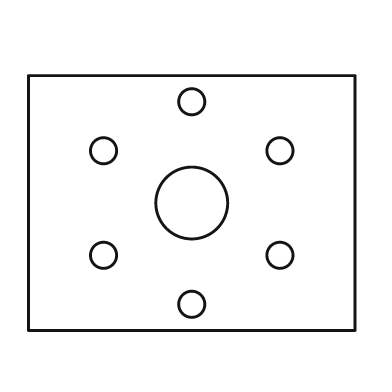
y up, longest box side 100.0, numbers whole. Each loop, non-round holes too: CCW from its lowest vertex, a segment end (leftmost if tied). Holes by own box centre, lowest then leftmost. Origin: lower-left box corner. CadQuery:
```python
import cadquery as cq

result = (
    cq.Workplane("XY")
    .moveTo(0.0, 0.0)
    .lineTo(100.0, 0.0)
    .lineTo(100.0, 78.0)
    .lineTo(0.0, 78.0)
    .close()
    .moveTo(50.0, 8.0)
    .circle(4.0)
    .moveTo(23.0, 23.0)
    .circle(4.0)
    .moveTo(77.0, 23.0)
    .circle(4.0)
    .moveTo(50.0, 39.0)
    .circle(11.0)
    .moveTo(23.0, 55.0)
    .circle(4.0)
    .moveTo(77.0, 55.0)
    .circle(4.0)
    .moveTo(50.0, 70.0)
    .circle(4.0)
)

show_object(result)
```